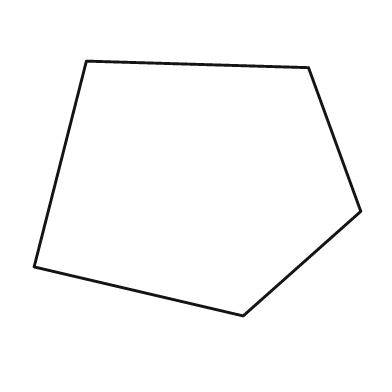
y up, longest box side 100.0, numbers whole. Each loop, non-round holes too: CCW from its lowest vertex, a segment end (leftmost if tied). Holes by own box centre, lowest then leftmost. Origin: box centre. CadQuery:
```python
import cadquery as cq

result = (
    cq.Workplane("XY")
    .moveTo(14.0, -39.0)
    .lineTo(50.0, -7.0)
    .lineTo(34.0, 37.0)
    .lineTo(-34.0, 39.0)
    .lineTo(-50.0, -24.0)
    .close()
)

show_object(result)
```